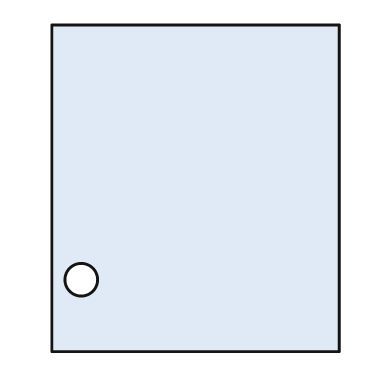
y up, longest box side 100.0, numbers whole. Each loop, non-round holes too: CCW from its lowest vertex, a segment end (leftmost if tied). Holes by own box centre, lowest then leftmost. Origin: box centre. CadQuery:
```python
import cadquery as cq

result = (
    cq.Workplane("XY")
    .moveTo(-44.0, -50.0)
    .lineTo(44.0, -50.0)
    .lineTo(44.0, 50.0)
    .lineTo(-44.0, 50.0)
    .close()
    .moveTo(-35.0, -28.0)
    .circle(5.0)
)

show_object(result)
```